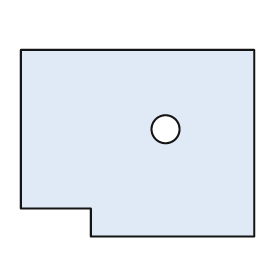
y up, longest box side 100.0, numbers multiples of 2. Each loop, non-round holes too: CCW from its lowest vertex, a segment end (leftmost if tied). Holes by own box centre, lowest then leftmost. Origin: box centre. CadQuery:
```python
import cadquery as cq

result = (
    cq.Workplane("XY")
    .moveTo(-20.0, -40.0)
    .lineTo(50.0, -40.0)
    .lineTo(50.0, 40.0)
    .lineTo(-50.0, 40.0)
    .lineTo(-50.0, -28.0)
    .lineTo(-20.0, -28.0)
    .close()
    .moveTo(12.0, 6.0)
    .circle(6.0)
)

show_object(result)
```